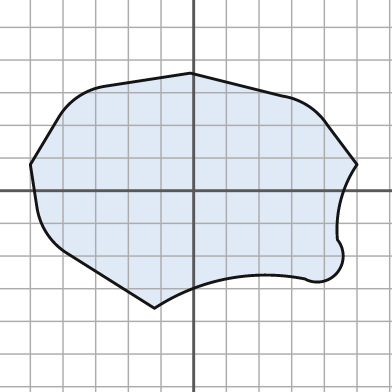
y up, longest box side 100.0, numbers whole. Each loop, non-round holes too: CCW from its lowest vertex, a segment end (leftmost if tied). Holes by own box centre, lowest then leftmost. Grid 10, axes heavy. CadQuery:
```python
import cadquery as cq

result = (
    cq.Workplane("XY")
    .moveTo(-12.0, -36.0)
    .threePointArc((10.0, -27.0), (34.0, -27.0))
    .threePointArc((44.0, -25.0), (44.0, -15.0))
    .threePointArc((45.0, -3.0), (50.0, 8.0))
    .lineTo(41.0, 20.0)
    .threePointArc((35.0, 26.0), (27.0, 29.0))
    .lineTo(-1.0, 36.0)
    .lineTo(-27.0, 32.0)
    .threePointArc((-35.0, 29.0), (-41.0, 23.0))
    .lineTo(-50.0, 8.0)
    .lineTo(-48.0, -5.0)
    .threePointArc((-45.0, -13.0), (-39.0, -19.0))
    .close()
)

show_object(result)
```